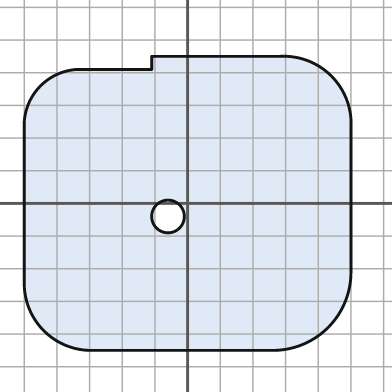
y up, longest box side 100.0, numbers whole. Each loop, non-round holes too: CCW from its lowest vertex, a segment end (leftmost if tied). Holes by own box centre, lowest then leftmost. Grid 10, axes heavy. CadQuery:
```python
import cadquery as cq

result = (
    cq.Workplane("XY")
    .moveTo(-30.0, -45.0)
    .lineTo(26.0, -45.0)
    .threePointArc((43.0, -38.0), (50.0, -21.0))
    .lineTo(50.0, 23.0)
    .threePointArc((44.0, 39.0), (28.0, 45.0))
    .lineTo(-11.0, 45.0)
    .lineTo(-11.0, 41.0)
    .lineTo(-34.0, 41.0)
    .threePointArc((-45.0, 36.0), (-50.0, 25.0))
    .lineTo(-50.0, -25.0)
    .threePointArc((-44.0, -39.0), (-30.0, -45.0))
    .close()
    .moveTo(-6.0, -4.0)
    .circle(5.0)
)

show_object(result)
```